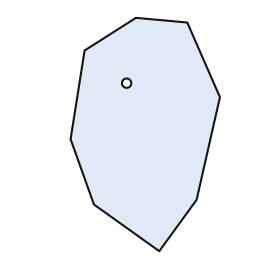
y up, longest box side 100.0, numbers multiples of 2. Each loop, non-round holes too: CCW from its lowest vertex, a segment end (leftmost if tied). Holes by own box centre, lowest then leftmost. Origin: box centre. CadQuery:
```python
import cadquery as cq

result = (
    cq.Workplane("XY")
    .moveTo(6.0, -50.0)
    .lineTo(22.0, -28.0)
    .lineTo(32.0, 16.0)
    .lineTo(18.0, 48.0)
    .lineTo(-4.0, 50.0)
    .lineTo(-26.0, 36.0)
    .lineTo(-32.0, -2.0)
    .lineTo(-22.0, -30.0)
    .close()
    .moveTo(-8.0, 22.0)
    .circle(2.0)
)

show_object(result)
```